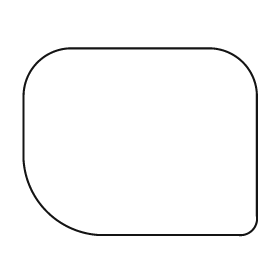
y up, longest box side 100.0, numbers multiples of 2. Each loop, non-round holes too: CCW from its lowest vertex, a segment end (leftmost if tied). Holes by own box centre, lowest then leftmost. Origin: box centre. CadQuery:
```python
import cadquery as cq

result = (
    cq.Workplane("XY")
    .moveTo(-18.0, -40.0)
    .lineTo(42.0, -40.0)
    .threePointArc((48.0, -38.0), (50.0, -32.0))
    .lineTo(50.0, 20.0)
    .threePointArc((44.0, 34.0), (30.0, 40.0))
    .lineTo(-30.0, 40.0)
    .threePointArc((-44.0, 34.0), (-50.0, 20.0))
    .lineTo(-50.0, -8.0)
    .threePointArc((-40.0, -30.0), (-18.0, -40.0))
    .close()
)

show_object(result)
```